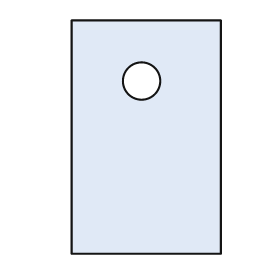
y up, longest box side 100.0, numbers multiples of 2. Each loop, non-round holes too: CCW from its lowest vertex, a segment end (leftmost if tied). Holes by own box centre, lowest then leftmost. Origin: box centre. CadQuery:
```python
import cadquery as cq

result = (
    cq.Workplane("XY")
    .moveTo(-32.0, -50.0)
    .lineTo(32.0, -50.0)
    .lineTo(32.0, 50.0)
    .lineTo(-32.0, 50.0)
    .close()
    .moveTo(-2.0, 24.0)
    .circle(8.0)
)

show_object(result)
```